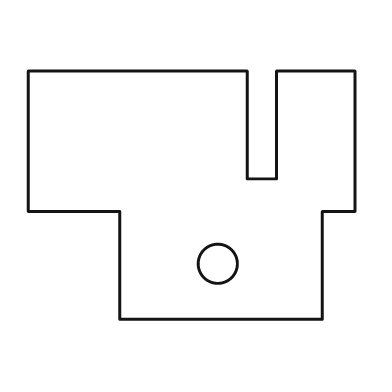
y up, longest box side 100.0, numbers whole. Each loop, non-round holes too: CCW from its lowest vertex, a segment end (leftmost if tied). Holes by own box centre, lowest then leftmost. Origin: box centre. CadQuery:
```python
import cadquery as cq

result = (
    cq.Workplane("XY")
    .moveTo(-22.0, -38.0)
    .lineTo(40.0, -38.0)
    .lineTo(40.0, -5.0)
    .lineTo(50.0, -5.0)
    .lineTo(50.0, 38.0)
    .lineTo(26.0, 38.0)
    .lineTo(26.0, 5.0)
    .lineTo(17.0, 5.0)
    .lineTo(17.0, 38.0)
    .lineTo(-50.0, 38.0)
    .lineTo(-50.0, -5.0)
    .lineTo(-22.0, -5.0)
    .close()
    .moveTo(8.0, -21.0)
    .circle(6.0)
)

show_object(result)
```